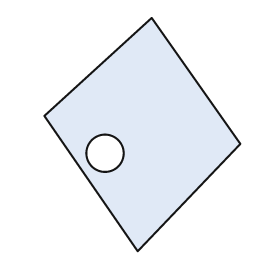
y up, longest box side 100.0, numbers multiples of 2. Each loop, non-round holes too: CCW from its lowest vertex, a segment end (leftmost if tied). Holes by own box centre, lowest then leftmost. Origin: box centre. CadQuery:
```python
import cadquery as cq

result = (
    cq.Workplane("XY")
    .moveTo(-2.0, -50.0)
    .lineTo(42.0, -4.0)
    .lineTo(4.0, 50.0)
    .lineTo(-42.0, 8.0)
    .close()
    .moveTo(-16.0, -8.0)
    .circle(8.0)
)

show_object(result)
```